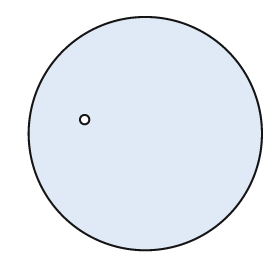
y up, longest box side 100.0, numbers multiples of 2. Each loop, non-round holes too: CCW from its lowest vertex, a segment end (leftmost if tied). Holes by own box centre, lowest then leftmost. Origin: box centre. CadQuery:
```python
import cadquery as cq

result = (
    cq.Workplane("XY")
    .moveTo(0.0, 0.0)
    .circle(50.0)
    .moveTo(-26.0, 6.0)
    .circle(2.0)
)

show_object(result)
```